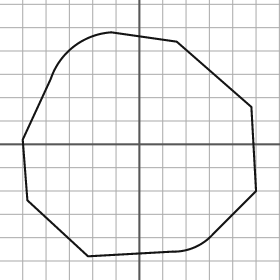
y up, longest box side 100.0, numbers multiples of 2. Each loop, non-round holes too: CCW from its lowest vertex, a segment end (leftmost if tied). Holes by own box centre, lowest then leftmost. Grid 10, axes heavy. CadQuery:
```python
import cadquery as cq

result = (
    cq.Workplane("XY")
    .moveTo(-22.0, -48.0)
    .lineTo(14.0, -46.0)
    .threePointArc((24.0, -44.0), (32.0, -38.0))
    .lineTo(50.0, -20.0)
    .lineTo(48.0, 16.0)
    .lineTo(16.0, 44.0)
    .lineTo(-12.0, 48.0)
    .threePointArc((-28.0, 42.0), (-38.0, 28.0))
    .lineTo(-50.0, 2.0)
    .lineTo(-48.0, -24.0)
    .close()
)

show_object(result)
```